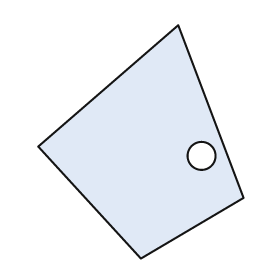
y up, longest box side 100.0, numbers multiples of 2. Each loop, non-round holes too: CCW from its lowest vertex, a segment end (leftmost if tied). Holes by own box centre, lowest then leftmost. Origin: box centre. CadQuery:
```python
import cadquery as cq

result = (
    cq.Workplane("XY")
    .moveTo(0.0, -50.0)
    .lineTo(44.0, -24.0)
    .lineTo(16.0, 50.0)
    .lineTo(-44.0, -2.0)
    .close()
    .moveTo(26.0, -6.0)
    .circle(6.0)
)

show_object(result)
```